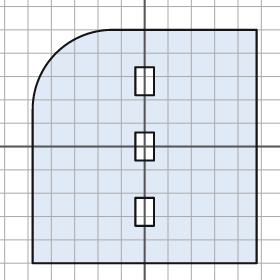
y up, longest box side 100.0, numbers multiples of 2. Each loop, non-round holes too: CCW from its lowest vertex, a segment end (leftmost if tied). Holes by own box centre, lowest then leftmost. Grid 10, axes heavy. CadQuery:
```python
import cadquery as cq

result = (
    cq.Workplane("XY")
    .moveTo(-48.0, -50.0)
    .lineTo(48.0, -50.0)
    .lineTo(48.0, 50.0)
    .lineTo(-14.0, 50.0)
    .threePointArc((-38.0, 40.0), (-48.0, 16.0))
    .close()
    .moveTo(-4.0, -34.0)
    .lineTo(4.0, -34.0)
    .lineTo(4.0, -22.0)
    .lineTo(-4.0, -22.0)
    .close()
    .moveTo(-4.0, -6.0)
    .lineTo(4.0, -6.0)
    .lineTo(4.0, 6.0)
    .lineTo(-4.0, 6.0)
    .close()
    .moveTo(-4.0, 22.0)
    .lineTo(4.0, 22.0)
    .lineTo(4.0, 34.0)
    .lineTo(-4.0, 34.0)
    .close()
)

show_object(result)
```